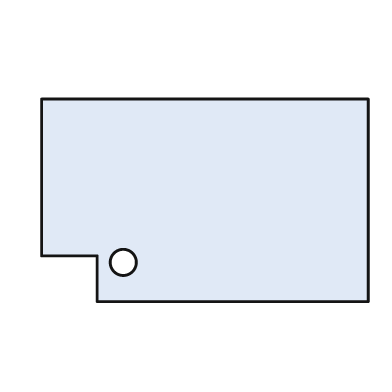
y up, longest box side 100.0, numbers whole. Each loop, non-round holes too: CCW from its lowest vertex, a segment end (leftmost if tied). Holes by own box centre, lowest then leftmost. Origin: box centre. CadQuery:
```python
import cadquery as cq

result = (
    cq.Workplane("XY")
    .moveTo(-33.0, -31.0)
    .lineTo(50.0, -31.0)
    .lineTo(50.0, 31.0)
    .lineTo(-50.0, 31.0)
    .lineTo(-50.0, -17.0)
    .lineTo(-33.0, -17.0)
    .close()
    .moveTo(-25.0, -19.0)
    .circle(4.0)
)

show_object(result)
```